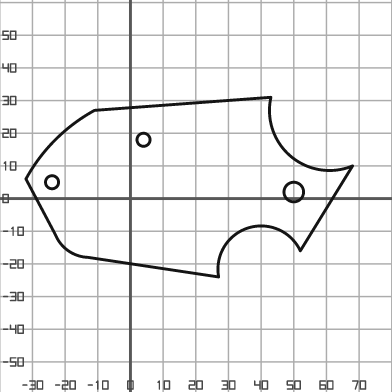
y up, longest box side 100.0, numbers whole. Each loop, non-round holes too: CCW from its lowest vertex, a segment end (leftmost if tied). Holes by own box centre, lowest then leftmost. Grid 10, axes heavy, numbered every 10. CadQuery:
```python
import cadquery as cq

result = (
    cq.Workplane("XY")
    .moveTo(27.0, -24.0)
    .threePointArc((36.0, -9.0), (52.0, -16.0))
    .lineTo(68.0, 10.0)
    .threePointArc((49.0, 13.0), (43.0, 31.0))
    .lineTo(-11.0, 27.0)
    .threePointArc((-23.0, 18.0), (-32.0, 6.0))
    .lineTo(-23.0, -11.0)
    .threePointArc((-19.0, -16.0), (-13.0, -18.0))
    .close()
    .moveTo(50.0, 2.0)
    .circle(3.0)
    .moveTo(-24.0, 5.0)
    .circle(2.0)
    .moveTo(4.0, 18.0)
    .circle(2.0)
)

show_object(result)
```